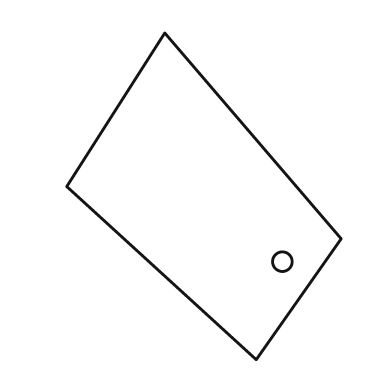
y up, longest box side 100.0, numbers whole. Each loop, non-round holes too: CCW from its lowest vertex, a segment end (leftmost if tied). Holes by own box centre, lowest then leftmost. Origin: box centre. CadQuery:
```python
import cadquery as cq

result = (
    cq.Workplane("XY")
    .moveTo(16.0, -50.0)
    .lineTo(42.0, -13.0)
    .lineTo(-12.0, 50.0)
    .lineTo(-42.0, 3.0)
    .close()
    .moveTo(24.0, -20.0)
    .circle(3.0)
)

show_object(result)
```